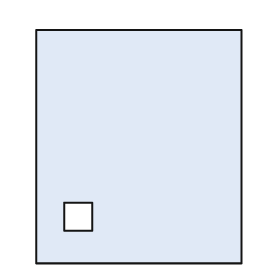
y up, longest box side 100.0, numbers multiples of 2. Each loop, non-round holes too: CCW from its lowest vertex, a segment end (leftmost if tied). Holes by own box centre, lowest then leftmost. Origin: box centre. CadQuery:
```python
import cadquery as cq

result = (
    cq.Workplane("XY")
    .moveTo(-44.0, -50.0)
    .lineTo(44.0, -50.0)
    .lineTo(44.0, 50.0)
    .lineTo(-44.0, 50.0)
    .close()
    .moveTo(-32.0, -36.0)
    .lineTo(-20.0, -36.0)
    .lineTo(-20.0, -24.0)
    .lineTo(-32.0, -24.0)
    .close()
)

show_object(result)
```